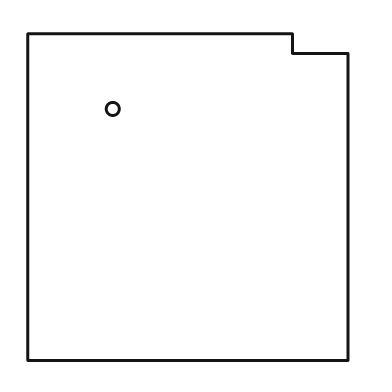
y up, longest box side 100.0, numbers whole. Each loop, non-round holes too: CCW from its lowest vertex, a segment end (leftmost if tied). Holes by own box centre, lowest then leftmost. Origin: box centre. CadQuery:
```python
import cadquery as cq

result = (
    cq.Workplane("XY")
    .moveTo(-49.0, -50.0)
    .lineTo(49.0, -50.0)
    .lineTo(49.0, 44.0)
    .lineTo(32.0, 44.0)
    .lineTo(32.0, 50.0)
    .lineTo(-49.0, 50.0)
    .close()
    .moveTo(-23.0, 27.0)
    .circle(2.0)
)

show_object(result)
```